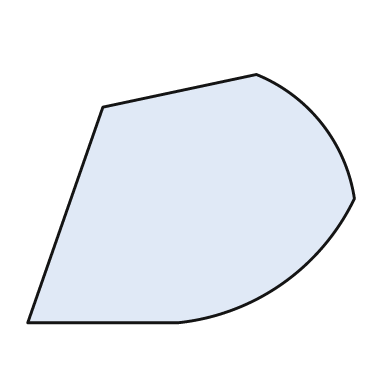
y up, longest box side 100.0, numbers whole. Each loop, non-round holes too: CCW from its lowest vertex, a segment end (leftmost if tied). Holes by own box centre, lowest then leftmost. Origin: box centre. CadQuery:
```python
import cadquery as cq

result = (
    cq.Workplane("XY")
    .moveTo(-50.0, -38.0)
    .lineTo(-4.0, -38.0)
    .threePointArc((28.0, -26.0), (50.0, 0.0))
    .threePointArc((40.0, 23.0), (20.0, 38.0))
    .lineTo(-27.0, 28.0)
    .close()
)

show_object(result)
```